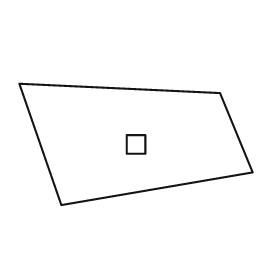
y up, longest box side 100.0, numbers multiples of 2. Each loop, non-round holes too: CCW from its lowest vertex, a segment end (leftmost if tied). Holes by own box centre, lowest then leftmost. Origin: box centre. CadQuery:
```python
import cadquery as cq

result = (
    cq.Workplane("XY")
    .moveTo(-32.0, -26.0)
    .lineTo(50.0, -12.0)
    .lineTo(36.0, 22.0)
    .lineTo(-50.0, 26.0)
    .close()
    .moveTo(-4.0, -4.0)
    .lineTo(4.0, -4.0)
    .lineTo(4.0, 4.0)
    .lineTo(-4.0, 4.0)
    .close()
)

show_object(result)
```